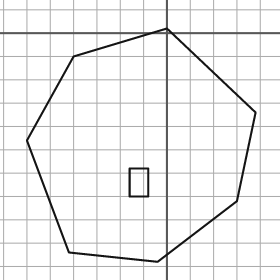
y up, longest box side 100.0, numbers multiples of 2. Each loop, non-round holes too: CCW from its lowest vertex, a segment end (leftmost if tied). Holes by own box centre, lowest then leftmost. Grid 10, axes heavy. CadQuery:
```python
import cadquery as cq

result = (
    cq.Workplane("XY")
    .moveTo(-4.0, -98.0)
    .lineTo(30.0, -72.0)
    .lineTo(38.0, -34.0)
    .lineTo(0.0, 2.0)
    .lineTo(-40.0, -10.0)
    .lineTo(-60.0, -46.0)
    .lineTo(-42.0, -94.0)
    .close()
    .moveTo(-16.0, -70.0)
    .lineTo(-8.0, -70.0)
    .lineTo(-8.0, -58.0)
    .lineTo(-16.0, -58.0)
    .close()
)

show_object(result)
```